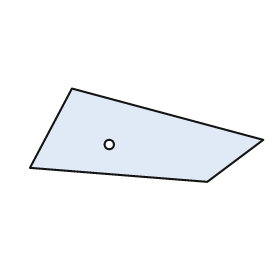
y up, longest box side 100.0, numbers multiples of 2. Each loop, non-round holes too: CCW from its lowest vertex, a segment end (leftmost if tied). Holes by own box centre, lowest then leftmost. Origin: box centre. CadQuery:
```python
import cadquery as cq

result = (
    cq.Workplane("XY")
    .moveTo(26.0, -20.0)
    .lineTo(50.0, -2.0)
    .lineTo(-32.0, 20.0)
    .lineTo(-50.0, -14.0)
    .close()
    .moveTo(-16.0, -4.0)
    .circle(2.0)
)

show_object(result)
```